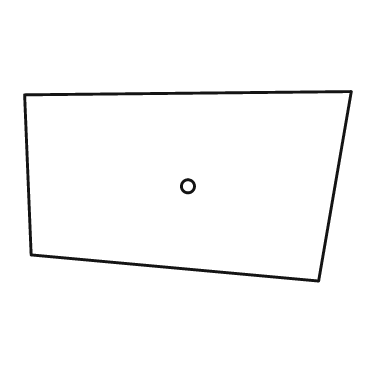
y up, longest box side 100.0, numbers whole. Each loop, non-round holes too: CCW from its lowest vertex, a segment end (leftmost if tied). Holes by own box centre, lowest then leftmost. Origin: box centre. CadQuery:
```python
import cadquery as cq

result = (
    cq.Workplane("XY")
    .moveTo(40.0, -29.0)
    .lineTo(50.0, 29.0)
    .lineTo(-50.0, 28.0)
    .lineTo(-48.0, -21.0)
    .close()
    .moveTo(0.0, 0.0)
    .circle(2.0)
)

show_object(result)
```